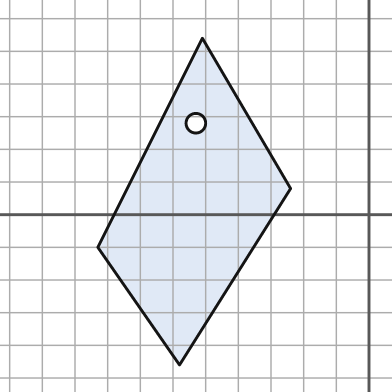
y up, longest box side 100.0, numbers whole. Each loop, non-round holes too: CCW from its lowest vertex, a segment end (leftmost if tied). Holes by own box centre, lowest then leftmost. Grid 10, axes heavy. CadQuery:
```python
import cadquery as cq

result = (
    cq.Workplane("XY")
    .moveTo(-58.0, -46.0)
    .lineTo(-24.0, 8.0)
    .lineTo(-51.0, 54.0)
    .lineTo(-83.0, -10.0)
    .close()
    .moveTo(-53.0, 28.0)
    .circle(3.0)
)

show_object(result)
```